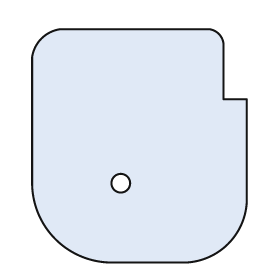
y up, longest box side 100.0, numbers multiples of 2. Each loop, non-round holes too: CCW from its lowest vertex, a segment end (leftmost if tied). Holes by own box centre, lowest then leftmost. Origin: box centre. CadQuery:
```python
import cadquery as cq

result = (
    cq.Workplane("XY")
    .moveTo(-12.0, -50.0)
    .lineTo(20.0, -50.0)
    .threePointArc((38.0, -42.0), (46.0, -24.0))
    .lineTo(46.0, 20.0)
    .lineTo(36.0, 20.0)
    .lineTo(36.0, 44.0)
    .threePointArc((34.0, 48.0), (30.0, 50.0))
    .lineTo(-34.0, 50.0)
    .threePointArc((-42.0, 46.0), (-46.0, 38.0))
    .lineTo(-46.0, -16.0)
    .threePointArc((-36.0, -40.0), (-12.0, -50.0))
    .close()
    .moveTo(-8.0, -16.0)
    .circle(4.0)
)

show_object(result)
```